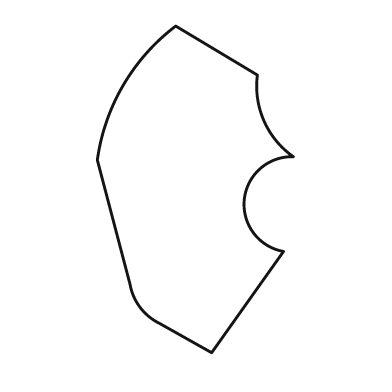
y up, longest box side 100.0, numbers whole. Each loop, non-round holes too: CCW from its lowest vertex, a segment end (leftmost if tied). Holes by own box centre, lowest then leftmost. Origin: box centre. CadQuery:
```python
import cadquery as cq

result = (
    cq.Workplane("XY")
    .moveTo(5.0, -50.0)
    .lineTo(27.0, -19.0)
    .threePointArc((15.0, -3.0), (30.0, 10.0))
    .threePointArc((21.0, 21.0), (19.0, 35.0))
    .lineTo(-6.0, 50.0)
    .threePointArc((-22.0, 32.0), (-30.0, 9.0))
    .lineTo(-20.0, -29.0)
    .threePointArc((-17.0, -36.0), (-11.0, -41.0))
    .close()
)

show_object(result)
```